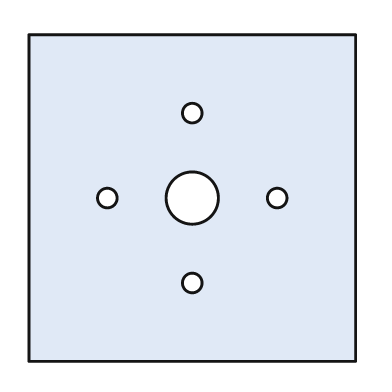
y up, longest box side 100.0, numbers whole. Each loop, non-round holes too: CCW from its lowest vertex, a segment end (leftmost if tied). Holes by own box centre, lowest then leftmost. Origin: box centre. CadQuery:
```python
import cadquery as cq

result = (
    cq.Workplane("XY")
    .moveTo(-50.0, -50.0)
    .lineTo(50.0, -50.0)
    .lineTo(50.0, 50.0)
    .lineTo(-50.0, 50.0)
    .close()
    .moveTo(0.0, -26.0)
    .circle(3.0)
    .moveTo(-26.0, 0.0)
    .circle(3.0)
    .moveTo(0.0, 0.0)
    .circle(8.0)
    .moveTo(26.0, 0.0)
    .circle(3.0)
    .moveTo(0.0, 26.0)
    .circle(3.0)
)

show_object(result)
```